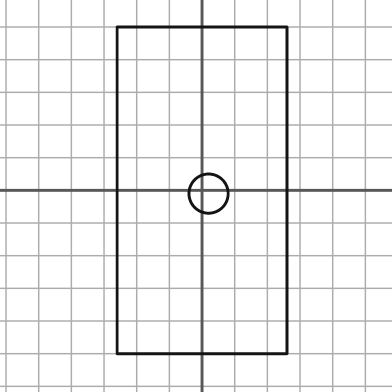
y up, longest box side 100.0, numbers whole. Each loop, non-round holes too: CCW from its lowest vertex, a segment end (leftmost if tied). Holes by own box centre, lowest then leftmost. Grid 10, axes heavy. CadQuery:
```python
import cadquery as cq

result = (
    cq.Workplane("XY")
    .moveTo(-26.0, -50.0)
    .lineTo(26.0, -50.0)
    .lineTo(26.0, 50.0)
    .lineTo(-26.0, 50.0)
    .close()
    .moveTo(2.0, -1.0)
    .circle(6.0)
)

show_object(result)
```